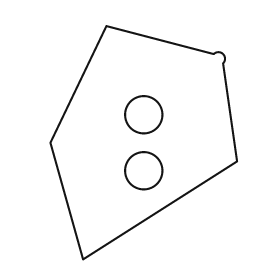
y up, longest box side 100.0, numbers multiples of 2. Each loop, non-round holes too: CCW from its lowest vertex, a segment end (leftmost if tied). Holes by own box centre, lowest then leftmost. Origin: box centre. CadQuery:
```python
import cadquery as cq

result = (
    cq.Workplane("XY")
    .moveTo(-26.0, -50.0)
    .lineTo(40.0, -8.0)
    .lineTo(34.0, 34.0)
    .threePointArc((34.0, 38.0), (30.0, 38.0))
    .lineTo(-16.0, 50.0)
    .lineTo(-40.0, 0.0)
    .close()
    .moveTo(0.0, -12.0)
    .circle(8.0)
    .moveTo(0.0, 12.0)
    .circle(8.0)
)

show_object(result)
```